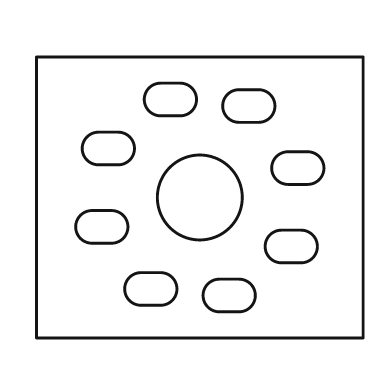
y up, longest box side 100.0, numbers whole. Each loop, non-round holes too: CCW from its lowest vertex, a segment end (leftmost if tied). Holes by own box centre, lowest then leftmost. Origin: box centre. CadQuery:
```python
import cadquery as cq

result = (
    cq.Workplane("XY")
    .moveTo(-50.0, -43.0)
    .lineTo(50.0, -43.0)
    .lineTo(50.0, 43.0)
    .lineTo(-50.0, 43.0)
    .close()
    .moveTo(6.0, -35.0)
    .lineTo(12.0, -35.0)
    .threePointArc((17.0, -30.0), (12.0, -25.0))
    .lineTo(6.0, -25.0)
    .threePointArc((1.0, -30.0), (6.0, -35.0))
    .close()
    .moveTo(-18.0, -33.0)
    .lineTo(-12.0, -33.0)
    .threePointArc((-7.0, -28.0), (-12.0, -23.0))
    .lineTo(-18.0, -23.0)
    .threePointArc((-23.0, -28.0), (-18.0, -33.0))
    .close()
    .moveTo(25.0, -20.0)
    .lineTo(31.0, -20.0)
    .threePointArc((36.0, -15.0), (31.0, -10.0))
    .lineTo(25.0, -10.0)
    .threePointArc((20.0, -15.0), (25.0, -20.0))
    .close()
    .moveTo(-33.0, -14.0)
    .lineTo(-27.0, -14.0)
    .threePointArc((-22.0, -9.0), (-27.0, -4.0))
    .lineTo(-33.0, -4.0)
    .threePointArc((-38.0, -9.0), (-33.0, -14.0))
    .close()
    .moveTo(0.0, 0.0)
    .circle(13.0)
    .moveTo(27.0, 4.0)
    .lineTo(33.0, 4.0)
    .threePointArc((38.0, 9.0), (33.0, 14.0))
    .lineTo(27.0, 14.0)
    .threePointArc((22.0, 9.0), (27.0, 4.0))
    .close()
    .moveTo(-31.0, 10.0)
    .lineTo(-25.0, 10.0)
    .threePointArc((-20.0, 15.0), (-25.0, 20.0))
    .lineTo(-31.0, 20.0)
    .threePointArc((-36.0, 15.0), (-31.0, 10.0))
    .close()
    .moveTo(12.0, 23.0)
    .lineTo(18.0, 23.0)
    .threePointArc((23.0, 28.0), (18.0, 33.0))
    .lineTo(12.0, 33.0)
    .threePointArc((7.0, 28.0), (12.0, 23.0))
    .close()
    .moveTo(-12.0, 25.0)
    .lineTo(-6.0, 25.0)
    .threePointArc((-1.0, 30.0), (-6.0, 35.0))
    .lineTo(-12.0, 35.0)
    .threePointArc((-17.0, 30.0), (-12.0, 25.0))
    .close()
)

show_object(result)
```